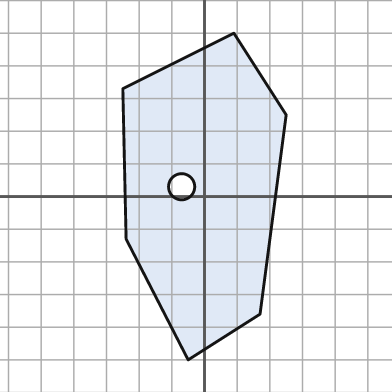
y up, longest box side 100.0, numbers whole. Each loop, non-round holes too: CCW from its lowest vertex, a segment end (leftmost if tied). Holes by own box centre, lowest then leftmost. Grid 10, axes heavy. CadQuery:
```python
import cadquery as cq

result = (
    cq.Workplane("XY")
    .moveTo(-5.0, -50.0)
    .lineTo(17.0, -36.0)
    .lineTo(25.0, 25.0)
    .lineTo(9.0, 50.0)
    .lineTo(-25.0, 33.0)
    .lineTo(-24.0, -13.0)
    .close()
    .moveTo(-7.0, 3.0)
    .circle(4.0)
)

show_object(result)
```